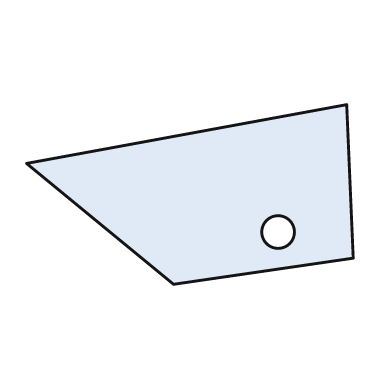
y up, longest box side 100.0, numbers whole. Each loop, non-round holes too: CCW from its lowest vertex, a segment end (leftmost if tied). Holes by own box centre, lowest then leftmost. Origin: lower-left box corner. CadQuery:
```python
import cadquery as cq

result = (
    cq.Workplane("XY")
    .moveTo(45.0, 0.0)
    .lineTo(100.0, 8.0)
    .lineTo(98.0, 55.0)
    .lineTo(0.0, 37.0)
    .close()
    .moveTo(77.0, 16.0)
    .circle(5.0)
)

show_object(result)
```